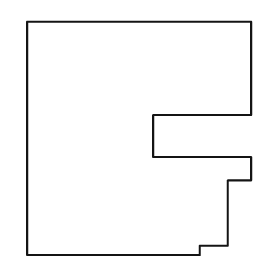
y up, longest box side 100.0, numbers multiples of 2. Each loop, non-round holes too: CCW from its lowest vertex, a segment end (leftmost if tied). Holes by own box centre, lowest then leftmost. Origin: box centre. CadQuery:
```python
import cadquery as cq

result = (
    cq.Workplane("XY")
    .moveTo(-48.0, -50.0)
    .lineTo(26.0, -50.0)
    .lineTo(26.0, -46.0)
    .lineTo(38.0, -46.0)
    .lineTo(38.0, -18.0)
    .lineTo(48.0, -18.0)
    .lineTo(48.0, -8.0)
    .lineTo(6.0, -8.0)
    .lineTo(6.0, 10.0)
    .lineTo(48.0, 10.0)
    .lineTo(48.0, 50.0)
    .lineTo(-48.0, 50.0)
    .close()
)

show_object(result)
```